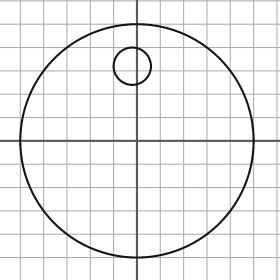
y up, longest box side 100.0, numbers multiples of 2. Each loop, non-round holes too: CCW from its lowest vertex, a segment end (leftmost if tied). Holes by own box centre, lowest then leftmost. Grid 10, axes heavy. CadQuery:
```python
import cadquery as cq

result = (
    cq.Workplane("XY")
    .moveTo(0.0, 0.0)
    .circle(50.0)
    .moveTo(-2.0, 32.0)
    .circle(8.0)
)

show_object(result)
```